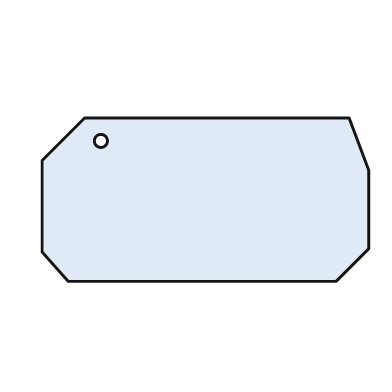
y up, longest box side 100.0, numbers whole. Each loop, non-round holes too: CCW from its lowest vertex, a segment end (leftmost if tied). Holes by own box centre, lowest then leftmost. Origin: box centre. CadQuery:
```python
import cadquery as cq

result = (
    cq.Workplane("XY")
    .moveTo(-42.0, -25.0)
    .lineTo(40.0, -25.0)
    .lineTo(50.0, -15.0)
    .lineTo(50.0, 9.0)
    .lineTo(44.0, 25.0)
    .lineTo(-37.0, 25.0)
    .lineTo(-50.0, 12.0)
    .lineTo(-50.0, -16.0)
    .close()
    .moveTo(-32.0, 18.0)
    .circle(2.0)
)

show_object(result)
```